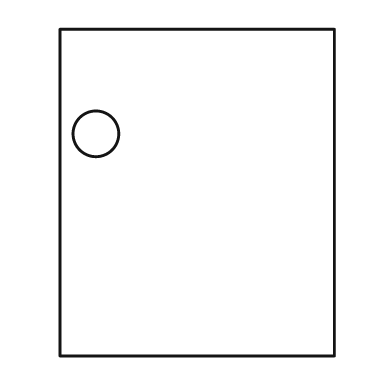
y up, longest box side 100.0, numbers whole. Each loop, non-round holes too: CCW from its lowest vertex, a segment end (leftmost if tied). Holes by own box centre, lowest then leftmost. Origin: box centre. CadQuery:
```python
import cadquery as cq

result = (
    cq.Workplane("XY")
    .moveTo(-42.0, -50.0)
    .lineTo(42.0, -50.0)
    .lineTo(42.0, 50.0)
    .lineTo(-42.0, 50.0)
    .close()
    .moveTo(-31.0, 18.0)
    .circle(7.0)
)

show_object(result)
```